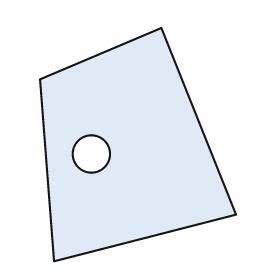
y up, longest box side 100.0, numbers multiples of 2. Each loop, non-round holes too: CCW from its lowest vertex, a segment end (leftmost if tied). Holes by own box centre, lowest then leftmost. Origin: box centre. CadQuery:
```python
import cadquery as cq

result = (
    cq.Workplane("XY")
    .moveTo(-36.0, -50.0)
    .lineTo(42.0, -30.0)
    .lineTo(10.0, 50.0)
    .lineTo(-42.0, 28.0)
    .close()
    .moveTo(-20.0, -4.0)
    .circle(8.0)
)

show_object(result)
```